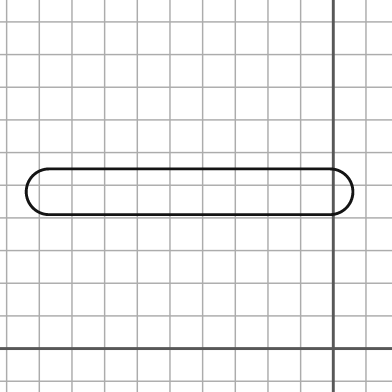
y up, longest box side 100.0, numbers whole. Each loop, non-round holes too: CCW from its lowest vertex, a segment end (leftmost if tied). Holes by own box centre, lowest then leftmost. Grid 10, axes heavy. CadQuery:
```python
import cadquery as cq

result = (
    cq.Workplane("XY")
    .moveTo(-87.0, 41.0)
    .lineTo(-1.0, 41.0)
    .threePointArc((6.0, 48.0), (-1.0, 55.0))
    .lineTo(-87.0, 55.0)
    .threePointArc((-94.0, 48.0), (-87.0, 41.0))
    .close()
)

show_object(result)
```